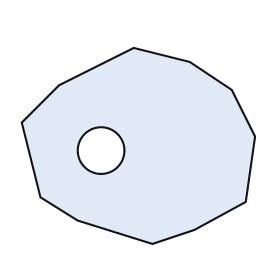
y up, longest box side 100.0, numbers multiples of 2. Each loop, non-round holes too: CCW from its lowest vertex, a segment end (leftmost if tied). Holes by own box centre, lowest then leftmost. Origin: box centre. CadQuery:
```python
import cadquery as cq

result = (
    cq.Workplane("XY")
    .moveTo(6.0, -42.0)
    .lineTo(24.0, -36.0)
    .lineTo(46.0, -24.0)
    .lineTo(50.0, 4.0)
    .lineTo(40.0, 24.0)
    .lineTo(22.0, 36.0)
    .lineTo(-2.0, 42.0)
    .lineTo(-34.0, 26.0)
    .lineTo(-50.0, 10.0)
    .lineTo(-42.0, -22.0)
    .lineTo(-26.0, -32.0)
    .close()
    .moveTo(-16.0, -2.0)
    .circle(10.0)
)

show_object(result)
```